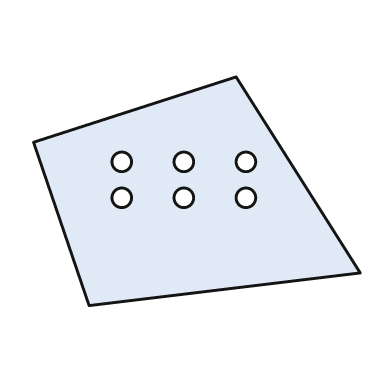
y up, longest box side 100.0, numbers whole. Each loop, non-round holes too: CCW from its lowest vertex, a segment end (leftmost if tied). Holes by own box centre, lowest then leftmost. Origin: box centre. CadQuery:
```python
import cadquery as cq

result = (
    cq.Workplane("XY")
    .moveTo(-33.0, -35.0)
    .lineTo(50.0, -25.0)
    .lineTo(12.0, 35.0)
    .lineTo(-50.0, 15.0)
    .close()
    .moveTo(-23.0, -2.0)
    .circle(3.0)
    .moveTo(-4.0, -2.0)
    .circle(3.0)
    .moveTo(15.0, -2.0)
    .circle(3.0)
    .moveTo(-23.0, 9.0)
    .circle(3.0)
    .moveTo(-4.0, 9.0)
    .circle(3.0)
    .moveTo(15.0, 9.0)
    .circle(3.0)
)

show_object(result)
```